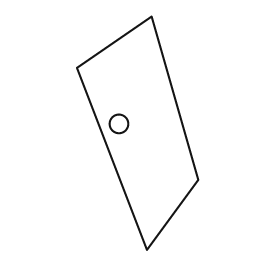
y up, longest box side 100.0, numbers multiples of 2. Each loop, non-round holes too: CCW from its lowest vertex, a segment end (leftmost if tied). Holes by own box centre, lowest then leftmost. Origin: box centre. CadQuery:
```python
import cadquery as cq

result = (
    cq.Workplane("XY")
    .moveTo(4.0, -50.0)
    .lineTo(26.0, -20.0)
    .lineTo(6.0, 50.0)
    .lineTo(-26.0, 28.0)
    .close()
    .moveTo(-8.0, 4.0)
    .circle(4.0)
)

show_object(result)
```